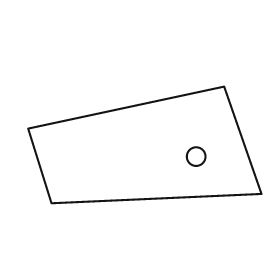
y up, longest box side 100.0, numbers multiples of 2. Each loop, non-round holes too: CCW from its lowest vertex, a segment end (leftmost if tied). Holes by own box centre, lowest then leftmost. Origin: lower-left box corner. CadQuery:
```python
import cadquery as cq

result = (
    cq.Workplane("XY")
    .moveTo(10.0, 0.0)
    .lineTo(100.0, 4.0)
    .lineTo(84.0, 50.0)
    .lineTo(0.0, 32.0)
    .close()
    .moveTo(72.0, 20.0)
    .circle(4.0)
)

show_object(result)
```